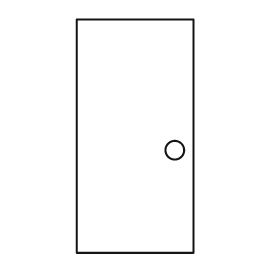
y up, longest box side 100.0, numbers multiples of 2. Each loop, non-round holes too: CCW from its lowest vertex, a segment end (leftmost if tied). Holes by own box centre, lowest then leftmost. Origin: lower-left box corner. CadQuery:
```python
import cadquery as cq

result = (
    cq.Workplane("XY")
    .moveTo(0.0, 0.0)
    .lineTo(50.0, 0.0)
    .lineTo(50.0, 100.0)
    .lineTo(0.0, 100.0)
    .close()
    .moveTo(42.0, 44.0)
    .circle(4.0)
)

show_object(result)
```